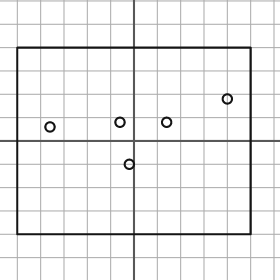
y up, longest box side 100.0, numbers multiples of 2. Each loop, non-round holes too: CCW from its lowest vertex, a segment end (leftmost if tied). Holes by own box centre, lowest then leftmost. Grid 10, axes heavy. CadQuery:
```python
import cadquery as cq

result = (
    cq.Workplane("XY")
    .moveTo(-50.0, -40.0)
    .lineTo(50.0, -40.0)
    .lineTo(50.0, 40.0)
    .lineTo(-50.0, 40.0)
    .close()
    .moveTo(-2.0, -10.0)
    .circle(2.0)
    .moveTo(-36.0, 6.0)
    .circle(2.0)
    .moveTo(-6.0, 8.0)
    .circle(2.0)
    .moveTo(14.0, 8.0)
    .circle(2.0)
    .moveTo(40.0, 18.0)
    .circle(2.0)
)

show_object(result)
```